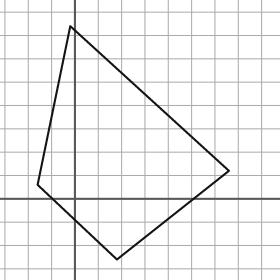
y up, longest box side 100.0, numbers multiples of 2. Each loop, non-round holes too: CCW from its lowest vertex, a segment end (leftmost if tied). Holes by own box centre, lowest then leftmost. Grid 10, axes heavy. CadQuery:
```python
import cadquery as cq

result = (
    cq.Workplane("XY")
    .moveTo(18.0, -26.0)
    .lineTo(66.0, 12.0)
    .lineTo(-2.0, 74.0)
    .lineTo(-16.0, 6.0)
    .close()
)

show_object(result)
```